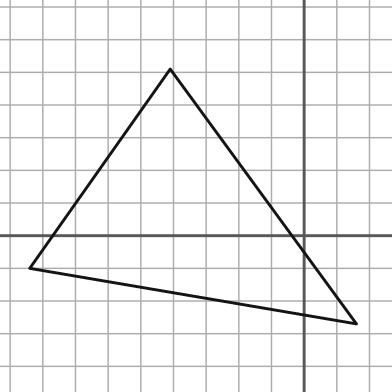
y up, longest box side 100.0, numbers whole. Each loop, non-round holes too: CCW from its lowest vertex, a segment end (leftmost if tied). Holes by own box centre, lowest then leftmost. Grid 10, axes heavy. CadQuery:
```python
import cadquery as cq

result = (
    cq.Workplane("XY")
    .moveTo(16.0, -27.0)
    .lineTo(-41.0, 51.0)
    .lineTo(-84.0, -10.0)
    .close()
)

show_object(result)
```